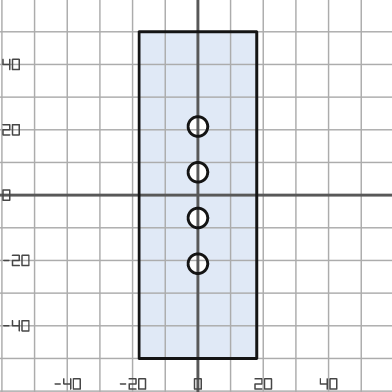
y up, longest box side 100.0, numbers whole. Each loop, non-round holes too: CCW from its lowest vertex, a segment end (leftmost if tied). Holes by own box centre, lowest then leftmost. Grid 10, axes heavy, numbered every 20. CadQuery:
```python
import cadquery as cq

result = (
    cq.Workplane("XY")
    .moveTo(-18.0, -50.0)
    .lineTo(18.0, -50.0)
    .lineTo(18.0, 50.0)
    .lineTo(-18.0, 50.0)
    .close()
    .moveTo(0.0, -21.0)
    .circle(3.0)
    .moveTo(0.0, -7.0)
    .circle(3.0)
    .moveTo(0.0, 7.0)
    .circle(3.0)
    .moveTo(0.0, 21.0)
    .circle(3.0)
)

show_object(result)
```